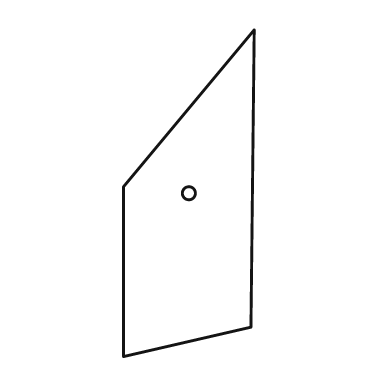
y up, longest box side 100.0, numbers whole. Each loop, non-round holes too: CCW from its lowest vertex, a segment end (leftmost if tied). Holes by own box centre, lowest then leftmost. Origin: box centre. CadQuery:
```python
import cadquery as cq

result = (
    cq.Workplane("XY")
    .moveTo(-20.0, -50.0)
    .lineTo(19.0, -41.0)
    .lineTo(20.0, 50.0)
    .lineTo(-20.0, 2.0)
    .close()
    .moveTo(0.0, 0.0)
    .circle(2.0)
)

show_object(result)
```